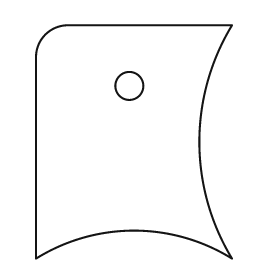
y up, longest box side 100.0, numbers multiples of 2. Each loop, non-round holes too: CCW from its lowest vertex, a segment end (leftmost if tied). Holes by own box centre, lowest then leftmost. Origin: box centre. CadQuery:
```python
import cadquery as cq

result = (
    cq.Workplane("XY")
    .moveTo(-42.0, -50.0)
    .threePointArc((0.0, -38.0), (42.0, -50.0))
    .threePointArc((28.0, 0.0), (42.0, 50.0))
    .lineTo(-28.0, 50.0)
    .threePointArc((-38.0, 46.0), (-42.0, 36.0))
    .close()
    .moveTo(-2.0, 24.0)
    .circle(6.0)
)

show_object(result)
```